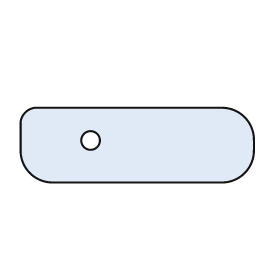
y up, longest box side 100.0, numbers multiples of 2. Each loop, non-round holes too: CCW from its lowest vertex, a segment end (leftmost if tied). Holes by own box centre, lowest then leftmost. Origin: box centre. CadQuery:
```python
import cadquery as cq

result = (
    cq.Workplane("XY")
    .moveTo(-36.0, -16.0)
    .lineTo(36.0, -16.0)
    .threePointArc((46.0, -12.0), (50.0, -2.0))
    .lineTo(50.0, 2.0)
    .threePointArc((46.0, 12.0), (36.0, 16.0))
    .lineTo(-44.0, 16.0)
    .threePointArc((-48.0, 14.0), (-50.0, 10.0))
    .lineTo(-50.0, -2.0)
    .threePointArc((-46.0, -12.0), (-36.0, -16.0))
    .close()
    .moveTo(-20.0, 2.0)
    .circle(4.0)
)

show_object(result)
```